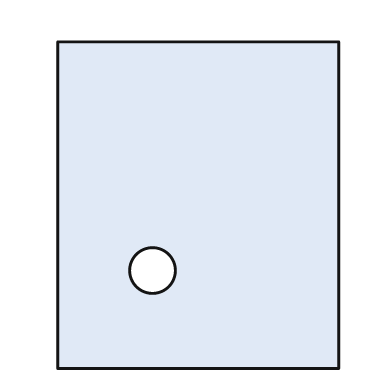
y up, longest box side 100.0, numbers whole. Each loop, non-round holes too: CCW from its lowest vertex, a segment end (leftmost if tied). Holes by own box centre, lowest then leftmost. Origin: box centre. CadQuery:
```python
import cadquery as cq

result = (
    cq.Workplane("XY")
    .moveTo(-43.0, -50.0)
    .lineTo(43.0, -50.0)
    .lineTo(43.0, 50.0)
    .lineTo(-43.0, 50.0)
    .close()
    .moveTo(-14.0, -20.0)
    .circle(7.0)
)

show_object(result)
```